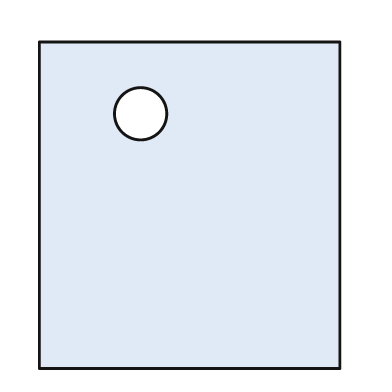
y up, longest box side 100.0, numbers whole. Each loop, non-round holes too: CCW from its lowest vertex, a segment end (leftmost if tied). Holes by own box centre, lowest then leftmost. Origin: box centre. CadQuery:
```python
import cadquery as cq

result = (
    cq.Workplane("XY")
    .moveTo(-46.0, -50.0)
    .lineTo(46.0, -50.0)
    .lineTo(46.0, 50.0)
    .lineTo(-46.0, 50.0)
    .close()
    .moveTo(-15.0, 28.0)
    .circle(8.0)
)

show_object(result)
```